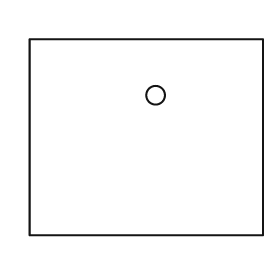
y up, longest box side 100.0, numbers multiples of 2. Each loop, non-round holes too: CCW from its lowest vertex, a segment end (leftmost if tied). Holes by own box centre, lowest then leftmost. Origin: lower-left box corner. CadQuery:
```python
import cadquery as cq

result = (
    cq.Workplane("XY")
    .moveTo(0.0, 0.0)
    .lineTo(100.0, 0.0)
    .lineTo(100.0, 84.0)
    .lineTo(0.0, 84.0)
    .close()
    .moveTo(54.0, 60.0)
    .circle(4.0)
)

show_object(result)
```